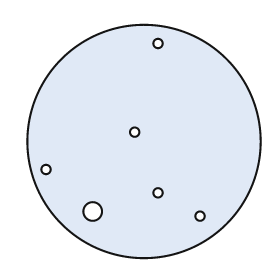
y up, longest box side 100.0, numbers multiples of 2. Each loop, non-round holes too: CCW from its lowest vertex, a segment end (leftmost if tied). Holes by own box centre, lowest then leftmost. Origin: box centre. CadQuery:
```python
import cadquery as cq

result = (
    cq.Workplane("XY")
    .moveTo(0.0, 0.0)
    .circle(50.0)
    .moveTo(24.0, -32.0)
    .circle(2.0)
    .moveTo(-22.0, -30.0)
    .circle(4.0)
    .moveTo(6.0, -22.0)
    .circle(2.0)
    .moveTo(-42.0, -12.0)
    .circle(2.0)
    .moveTo(-4.0, 4.0)
    .circle(2.0)
    .moveTo(6.0, 42.0)
    .circle(2.0)
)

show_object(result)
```